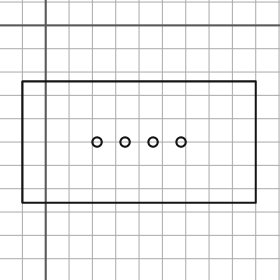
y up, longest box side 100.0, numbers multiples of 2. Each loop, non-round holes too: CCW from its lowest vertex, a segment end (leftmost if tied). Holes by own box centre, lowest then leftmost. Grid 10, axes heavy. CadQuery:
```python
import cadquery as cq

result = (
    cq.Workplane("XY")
    .moveTo(-10.0, -76.0)
    .lineTo(90.0, -76.0)
    .lineTo(90.0, -24.0)
    .lineTo(-10.0, -24.0)
    .close()
    .moveTo(22.0, -50.0)
    .circle(2.0)
    .moveTo(34.0, -50.0)
    .circle(2.0)
    .moveTo(46.0, -50.0)
    .circle(2.0)
    .moveTo(58.0, -50.0)
    .circle(2.0)
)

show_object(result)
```